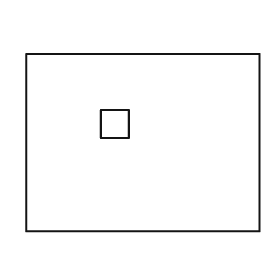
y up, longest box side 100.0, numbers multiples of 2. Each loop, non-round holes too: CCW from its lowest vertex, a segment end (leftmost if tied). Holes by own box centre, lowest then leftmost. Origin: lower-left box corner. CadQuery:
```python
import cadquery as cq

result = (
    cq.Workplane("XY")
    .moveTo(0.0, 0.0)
    .lineTo(100.0, 0.0)
    .lineTo(100.0, 76.0)
    .lineTo(0.0, 76.0)
    .close()
    .moveTo(32.0, 40.0)
    .lineTo(44.0, 40.0)
    .lineTo(44.0, 52.0)
    .lineTo(32.0, 52.0)
    .close()
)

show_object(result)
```